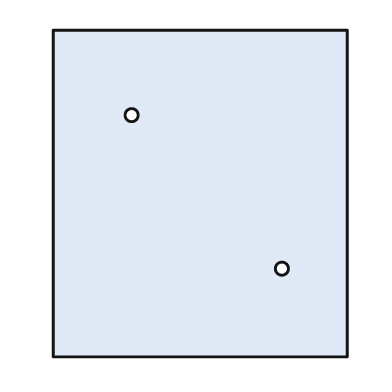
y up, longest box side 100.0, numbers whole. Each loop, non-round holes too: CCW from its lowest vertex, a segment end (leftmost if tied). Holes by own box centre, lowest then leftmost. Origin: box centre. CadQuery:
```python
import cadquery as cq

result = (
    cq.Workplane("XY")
    .moveTo(-45.0, -50.0)
    .lineTo(45.0, -50.0)
    .lineTo(45.0, 50.0)
    .lineTo(-45.0, 50.0)
    .close()
    .moveTo(25.0, -23.0)
    .circle(2.0)
    .moveTo(-21.0, 24.0)
    .circle(2.0)
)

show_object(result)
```